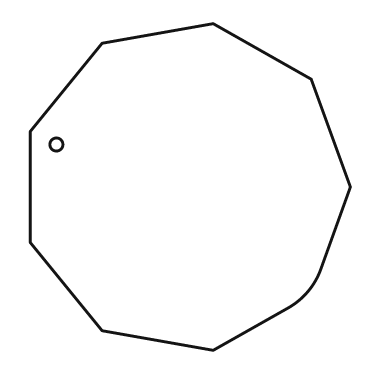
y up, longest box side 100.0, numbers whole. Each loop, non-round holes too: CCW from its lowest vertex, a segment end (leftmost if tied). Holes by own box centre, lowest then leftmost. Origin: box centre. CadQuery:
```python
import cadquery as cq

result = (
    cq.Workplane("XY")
    .moveTo(7.0, -50.0)
    .lineTo(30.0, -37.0)
    .threePointArc((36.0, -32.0), (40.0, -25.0))
    .lineTo(49.0, 0.0)
    .lineTo(37.0, 33.0)
    .lineTo(7.0, 50.0)
    .lineTo(-27.0, 44.0)
    .lineTo(-49.0, 17.0)
    .lineTo(-49.0, -17.0)
    .lineTo(-27.0, -44.0)
    .close()
    .moveTo(-41.0, 13.0)
    .circle(2.0)
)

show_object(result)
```